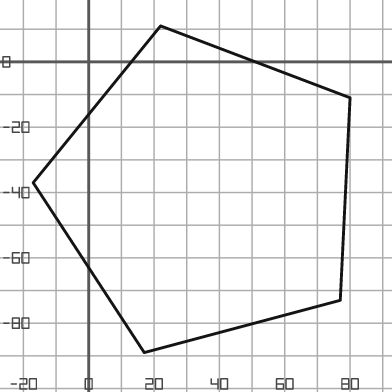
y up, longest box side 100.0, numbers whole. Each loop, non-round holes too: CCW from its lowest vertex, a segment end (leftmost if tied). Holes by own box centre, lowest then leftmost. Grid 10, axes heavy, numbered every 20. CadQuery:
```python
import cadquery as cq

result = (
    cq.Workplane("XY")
    .moveTo(17.0, -89.0)
    .lineTo(77.0, -73.0)
    .lineTo(80.0, -11.0)
    .lineTo(22.0, 11.0)
    .lineTo(-17.0, -37.0)
    .close()
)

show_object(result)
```